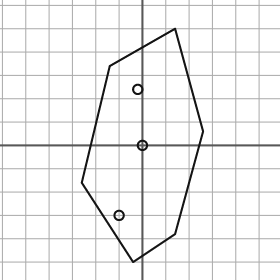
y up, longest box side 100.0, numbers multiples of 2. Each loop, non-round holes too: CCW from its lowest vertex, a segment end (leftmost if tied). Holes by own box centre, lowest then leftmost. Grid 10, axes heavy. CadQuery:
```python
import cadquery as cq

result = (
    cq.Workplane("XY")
    .moveTo(-4.0, -50.0)
    .lineTo(14.0, -38.0)
    .lineTo(26.0, 6.0)
    .lineTo(14.0, 50.0)
    .lineTo(-14.0, 34.0)
    .lineTo(-26.0, -16.0)
    .close()
    .moveTo(-10.0, -30.0)
    .circle(2.0)
    .moveTo(0.0, 0.0)
    .circle(2.0)
    .moveTo(-2.0, 24.0)
    .circle(2.0)
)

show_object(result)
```